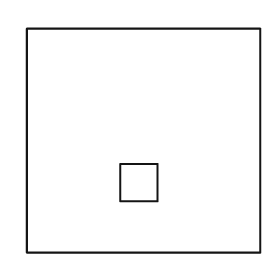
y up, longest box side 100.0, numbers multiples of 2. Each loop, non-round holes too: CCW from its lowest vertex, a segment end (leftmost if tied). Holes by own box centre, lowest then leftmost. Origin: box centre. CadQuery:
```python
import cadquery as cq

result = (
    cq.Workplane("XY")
    .moveTo(-50.0, -48.0)
    .lineTo(50.0, -48.0)
    .lineTo(50.0, 48.0)
    .lineTo(-50.0, 48.0)
    .close()
    .moveTo(-10.0, -26.0)
    .lineTo(6.0, -26.0)
    .lineTo(6.0, -10.0)
    .lineTo(-10.0, -10.0)
    .close()
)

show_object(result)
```